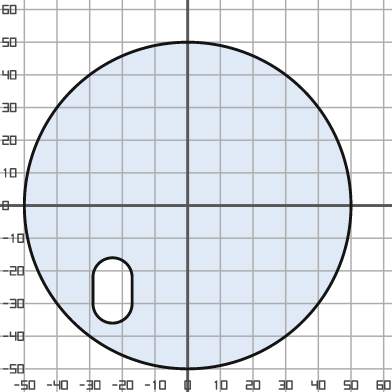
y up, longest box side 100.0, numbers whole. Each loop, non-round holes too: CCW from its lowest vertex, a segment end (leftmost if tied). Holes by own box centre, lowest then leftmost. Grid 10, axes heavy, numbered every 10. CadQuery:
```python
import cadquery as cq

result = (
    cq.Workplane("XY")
    .moveTo(0.0, 0.0)
    .circle(50.0)
    .moveTo(-29.0, -30.0)
    .threePointArc((-23.0, -36.0), (-17.0, -30.0))
    .lineTo(-17.0, -22.0)
    .threePointArc((-23.0, -16.0), (-29.0, -22.0))
    .close()
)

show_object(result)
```